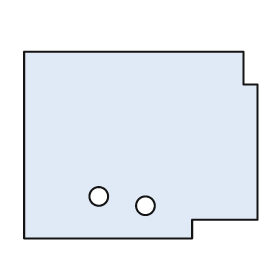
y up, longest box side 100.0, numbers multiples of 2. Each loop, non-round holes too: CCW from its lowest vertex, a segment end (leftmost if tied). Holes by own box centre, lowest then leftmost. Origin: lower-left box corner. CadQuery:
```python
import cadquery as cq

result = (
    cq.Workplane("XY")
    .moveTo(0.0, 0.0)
    .lineTo(72.0, 0.0)
    .lineTo(72.0, 8.0)
    .lineTo(100.0, 8.0)
    .lineTo(100.0, 66.0)
    .lineTo(94.0, 66.0)
    .lineTo(94.0, 80.0)
    .lineTo(0.0, 80.0)
    .close()
    .moveTo(52.0, 14.0)
    .circle(4.0)
    .moveTo(32.0, 18.0)
    .circle(4.0)
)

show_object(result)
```